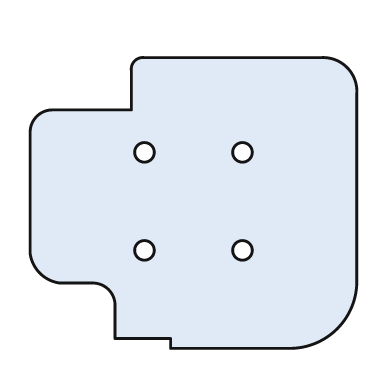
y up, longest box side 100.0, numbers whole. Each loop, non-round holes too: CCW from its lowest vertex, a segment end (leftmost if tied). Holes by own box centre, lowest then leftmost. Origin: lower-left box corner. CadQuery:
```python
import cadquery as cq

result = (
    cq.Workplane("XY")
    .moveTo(43.0, 0.0)
    .lineTo(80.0, 0.0)
    .threePointArc((94.0, 6.0), (100.0, 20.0))
    .lineTo(100.0, 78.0)
    .threePointArc((97.0, 86.0), (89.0, 89.0))
    .lineTo(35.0, 89.0)
    .threePointArc((32.0, 88.0), (31.0, 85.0))
    .lineTo(31.0, 73.0)
    .lineTo(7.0, 73.0)
    .threePointArc((2.0, 71.0), (0.0, 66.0))
    .lineTo(0.0, 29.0)
    .threePointArc((3.0, 23.0), (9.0, 20.0))
    .lineTo(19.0, 20.0)
    .threePointArc((24.0, 18.0), (26.0, 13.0))
    .lineTo(26.0, 3.0)
    .lineTo(43.0, 3.0)
    .close()
    .moveTo(35.0, 30.0)
    .circle(3.0)
    .moveTo(65.0, 30.0)
    .circle(3.0)
    .moveTo(35.0, 60.0)
    .circle(3.0)
    .moveTo(65.0, 60.0)
    .circle(3.0)
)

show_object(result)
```